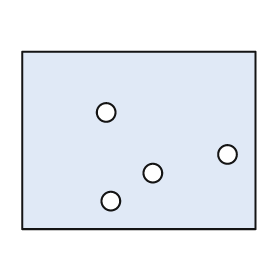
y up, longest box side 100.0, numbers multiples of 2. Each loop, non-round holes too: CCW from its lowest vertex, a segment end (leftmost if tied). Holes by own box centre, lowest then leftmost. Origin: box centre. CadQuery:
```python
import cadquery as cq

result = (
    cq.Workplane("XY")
    .moveTo(-50.0, -38.0)
    .lineTo(50.0, -38.0)
    .lineTo(50.0, 38.0)
    .lineTo(-50.0, 38.0)
    .close()
    .moveTo(-12.0, -26.0)
    .circle(4.0)
    .moveTo(6.0, -14.0)
    .circle(4.0)
    .moveTo(38.0, -6.0)
    .circle(4.0)
    .moveTo(-14.0, 12.0)
    .circle(4.0)
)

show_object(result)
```